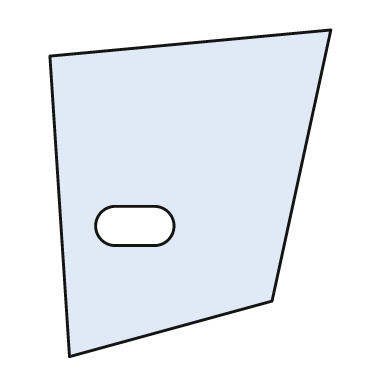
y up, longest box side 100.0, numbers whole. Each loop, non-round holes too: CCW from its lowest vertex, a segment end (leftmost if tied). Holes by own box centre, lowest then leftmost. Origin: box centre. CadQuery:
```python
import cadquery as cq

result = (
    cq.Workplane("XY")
    .moveTo(-37.0, -50.0)
    .lineTo(25.0, -33.0)
    .lineTo(43.0, 50.0)
    .lineTo(-43.0, 42.0)
    .close()
    .moveTo(-23.0, -16.0)
    .lineTo(-11.0, -16.0)
    .threePointArc((-5.0, -10.0), (-11.0, -4.0))
    .lineTo(-23.0, -4.0)
    .threePointArc((-29.0, -10.0), (-23.0, -16.0))
    .close()
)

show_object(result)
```